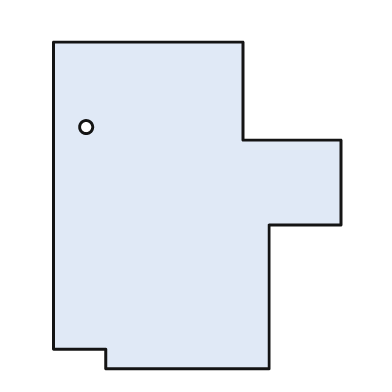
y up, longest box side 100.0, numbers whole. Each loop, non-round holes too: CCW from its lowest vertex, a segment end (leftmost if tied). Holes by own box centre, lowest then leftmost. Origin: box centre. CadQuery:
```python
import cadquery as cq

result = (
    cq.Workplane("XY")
    .moveTo(-28.0, -50.0)
    .lineTo(22.0, -50.0)
    .lineTo(22.0, -6.0)
    .lineTo(44.0, -6.0)
    .lineTo(44.0, 20.0)
    .lineTo(14.0, 20.0)
    .lineTo(14.0, 50.0)
    .lineTo(-44.0, 50.0)
    .lineTo(-44.0, -44.0)
    .lineTo(-28.0, -44.0)
    .close()
    .moveTo(-34.0, 24.0)
    .circle(2.0)
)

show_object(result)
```